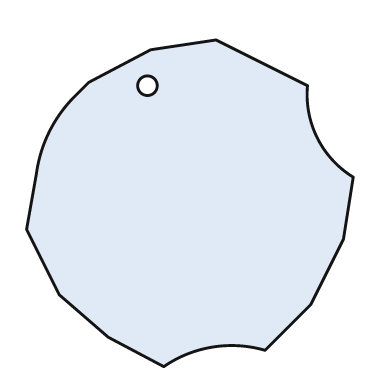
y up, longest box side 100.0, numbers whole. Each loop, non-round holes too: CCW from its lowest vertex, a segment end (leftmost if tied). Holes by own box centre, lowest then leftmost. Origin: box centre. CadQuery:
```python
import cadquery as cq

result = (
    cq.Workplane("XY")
    .moveTo(-8.0, -50.0)
    .threePointArc((7.0, -44.0), (23.0, -45.0))
    .lineTo(37.0, -31.0)
    .lineTo(47.0, -11.0)
    .lineTo(50.0, 8.0)
    .threePointArc((39.0, 20.0), (36.0, 36.0))
    .lineTo(8.0, 50.0)
    .lineTo(-12.0, 47.0)
    .lineTo(-31.0, 37.0)
    .lineTo(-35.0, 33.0)
    .threePointArc((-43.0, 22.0), (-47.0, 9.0))
    .lineTo(-50.0, -8.0)
    .lineTo(-40.0, -28.0)
    .lineTo(-25.0, -41.0)
    .close()
    .moveTo(-13.0, 36.0)
    .circle(3.0)
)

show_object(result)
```